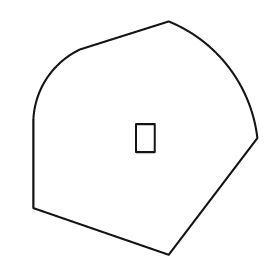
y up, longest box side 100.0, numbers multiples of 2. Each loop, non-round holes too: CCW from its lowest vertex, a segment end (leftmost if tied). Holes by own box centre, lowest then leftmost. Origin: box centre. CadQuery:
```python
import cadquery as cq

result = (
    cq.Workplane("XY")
    .moveTo(10.0, -50.0)
    .lineTo(48.0, 0.0)
    .threePointArc((36.0, 30.0), (10.0, 50.0))
    .lineTo(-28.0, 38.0)
    .threePointArc((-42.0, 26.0), (-48.0, 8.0))
    .lineTo(-48.0, -30.0)
    .close()
    .moveTo(-4.0, -6.0)
    .lineTo(4.0, -6.0)
    .lineTo(4.0, 6.0)
    .lineTo(-4.0, 6.0)
    .close()
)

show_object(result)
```